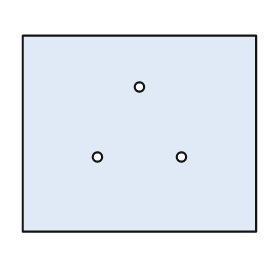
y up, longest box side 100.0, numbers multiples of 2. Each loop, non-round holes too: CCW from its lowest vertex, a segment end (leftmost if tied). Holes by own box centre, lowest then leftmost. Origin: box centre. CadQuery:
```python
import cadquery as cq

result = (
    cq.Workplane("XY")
    .moveTo(-50.0, -42.0)
    .lineTo(50.0, -42.0)
    .lineTo(50.0, 42.0)
    .lineTo(-50.0, 42.0)
    .close()
    .moveTo(-18.0, -10.0)
    .circle(2.0)
    .moveTo(18.0, -10.0)
    .circle(2.0)
    .moveTo(0.0, 20.0)
    .circle(2.0)
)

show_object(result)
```